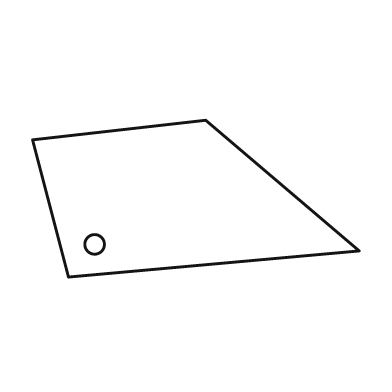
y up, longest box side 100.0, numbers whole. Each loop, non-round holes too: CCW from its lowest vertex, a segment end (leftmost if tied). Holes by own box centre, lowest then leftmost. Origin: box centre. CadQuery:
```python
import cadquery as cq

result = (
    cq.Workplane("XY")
    .moveTo(-39.0, -24.0)
    .lineTo(50.0, -16.0)
    .lineTo(3.0, 24.0)
    .lineTo(-50.0, 18.0)
    .close()
    .moveTo(-31.0, -14.0)
    .circle(3.0)
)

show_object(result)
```